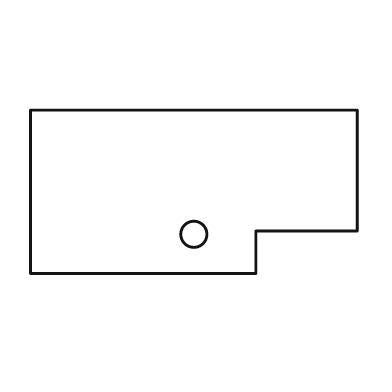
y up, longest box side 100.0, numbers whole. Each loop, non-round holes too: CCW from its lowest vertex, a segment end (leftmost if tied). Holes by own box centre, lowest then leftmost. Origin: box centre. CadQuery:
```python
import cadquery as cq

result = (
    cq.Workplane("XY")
    .moveTo(-50.0, -25.0)
    .lineTo(19.0, -25.0)
    .lineTo(19.0, -12.0)
    .lineTo(50.0, -12.0)
    .lineTo(50.0, 25.0)
    .lineTo(-50.0, 25.0)
    .close()
    .moveTo(0.0, -13.0)
    .circle(4.0)
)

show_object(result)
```